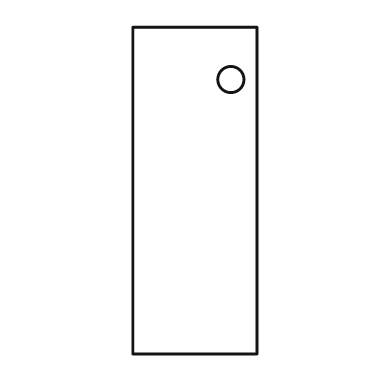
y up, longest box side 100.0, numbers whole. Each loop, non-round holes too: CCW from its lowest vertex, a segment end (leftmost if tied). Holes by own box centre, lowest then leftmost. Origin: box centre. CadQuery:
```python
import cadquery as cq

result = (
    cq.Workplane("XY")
    .moveTo(-19.0, -50.0)
    .lineTo(19.0, -50.0)
    .lineTo(19.0, 50.0)
    .lineTo(-19.0, 50.0)
    .close()
    .moveTo(11.0, 34.0)
    .circle(4.0)
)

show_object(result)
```